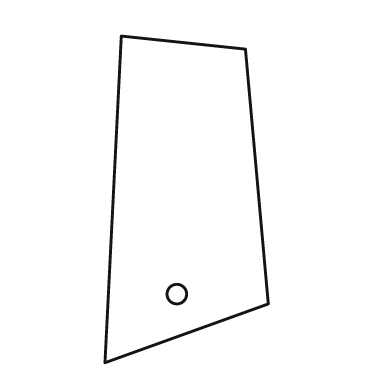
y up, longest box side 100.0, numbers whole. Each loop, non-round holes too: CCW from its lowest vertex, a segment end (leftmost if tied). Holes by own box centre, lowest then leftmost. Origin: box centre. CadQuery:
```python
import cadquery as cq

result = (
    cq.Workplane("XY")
    .moveTo(-25.0, -50.0)
    .lineTo(25.0, -32.0)
    .lineTo(18.0, 46.0)
    .lineTo(-20.0, 50.0)
    .close()
    .moveTo(-3.0, -29.0)
    .circle(3.0)
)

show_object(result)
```